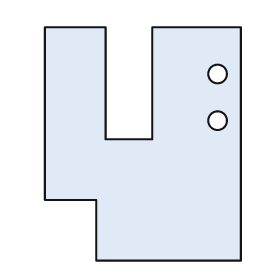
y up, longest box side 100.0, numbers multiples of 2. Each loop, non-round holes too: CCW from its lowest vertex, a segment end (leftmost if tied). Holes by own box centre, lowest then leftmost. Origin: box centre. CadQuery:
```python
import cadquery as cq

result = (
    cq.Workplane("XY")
    .moveTo(-20.0, -50.0)
    .lineTo(42.0, -50.0)
    .lineTo(42.0, 50.0)
    .lineTo(4.0, 50.0)
    .lineTo(4.0, 2.0)
    .lineTo(-16.0, 2.0)
    .lineTo(-16.0, 50.0)
    .lineTo(-42.0, 50.0)
    .lineTo(-42.0, -24.0)
    .lineTo(-20.0, -24.0)
    .close()
    .moveTo(32.0, 10.0)
    .circle(4.0)
    .moveTo(32.0, 30.0)
    .circle(4.0)
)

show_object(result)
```